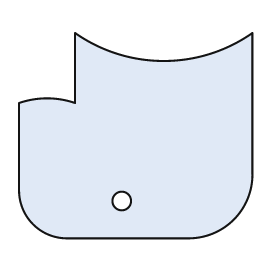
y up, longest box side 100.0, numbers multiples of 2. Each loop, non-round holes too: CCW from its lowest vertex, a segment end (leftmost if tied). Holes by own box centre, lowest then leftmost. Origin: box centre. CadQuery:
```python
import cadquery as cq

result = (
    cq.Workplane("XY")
    .moveTo(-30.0, -44.0)
    .lineTo(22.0, -44.0)
    .threePointArc((42.0, -36.0), (50.0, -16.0))
    .lineTo(50.0, 44.0)
    .threePointArc((12.0, 32.0), (-26.0, 44.0))
    .lineTo(-26.0, 14.0)
    .threePointArc((-38.0, 16.0), (-50.0, 14.0))
    .lineTo(-50.0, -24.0)
    .threePointArc((-44.0, -38.0), (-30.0, -44.0))
    .close()
    .moveTo(-6.0, -28.0)
    .circle(4.0)
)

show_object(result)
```